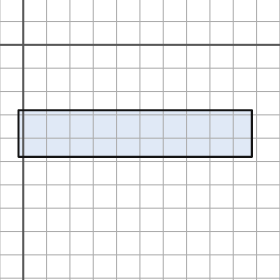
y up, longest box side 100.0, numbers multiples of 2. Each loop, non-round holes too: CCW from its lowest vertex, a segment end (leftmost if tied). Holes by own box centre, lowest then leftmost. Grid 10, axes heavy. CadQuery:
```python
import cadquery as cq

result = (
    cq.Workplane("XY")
    .moveTo(-2.0, -48.0)
    .lineTo(98.0, -48.0)
    .lineTo(98.0, -28.0)
    .lineTo(-2.0, -28.0)
    .close()
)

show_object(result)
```